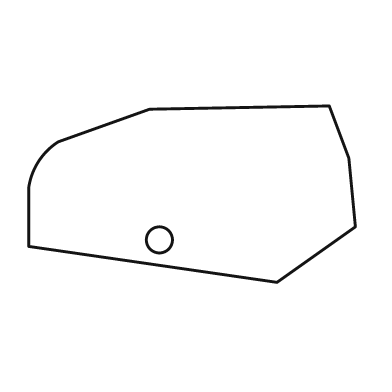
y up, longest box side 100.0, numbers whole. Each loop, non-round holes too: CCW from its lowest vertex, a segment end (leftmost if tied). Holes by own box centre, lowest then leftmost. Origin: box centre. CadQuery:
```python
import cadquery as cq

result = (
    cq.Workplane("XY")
    .moveTo(26.0, -27.0)
    .lineTo(50.0, -10.0)
    .lineTo(48.0, 11.0)
    .lineTo(42.0, 27.0)
    .lineTo(-13.0, 26.0)
    .lineTo(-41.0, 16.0)
    .threePointArc((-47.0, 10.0), (-50.0, 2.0))
    .lineTo(-50.0, -16.0)
    .close()
    .moveTo(-10.0, -14.0)
    .circle(4.0)
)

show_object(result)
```